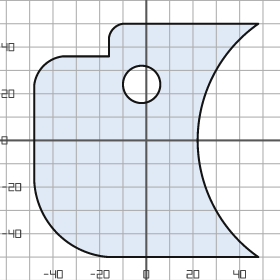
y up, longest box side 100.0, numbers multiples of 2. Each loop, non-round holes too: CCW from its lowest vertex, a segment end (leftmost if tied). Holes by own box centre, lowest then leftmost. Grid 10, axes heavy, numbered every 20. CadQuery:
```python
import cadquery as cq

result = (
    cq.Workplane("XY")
    .moveTo(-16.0, -50.0)
    .lineTo(48.0, -50.0)
    .threePointArc((22.0, 0.0), (48.0, 50.0))
    .lineTo(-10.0, 50.0)
    .threePointArc((-14.0, 48.0), (-16.0, 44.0))
    .lineTo(-16.0, 36.0)
    .lineTo(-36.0, 36.0)
    .threePointArc((-44.0, 32.0), (-48.0, 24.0))
    .lineTo(-48.0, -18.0)
    .threePointArc((-38.0, -40.0), (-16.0, -50.0))
    .close()
    .moveTo(-2.0, 24.0)
    .circle(8.0)
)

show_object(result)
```